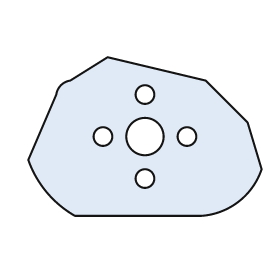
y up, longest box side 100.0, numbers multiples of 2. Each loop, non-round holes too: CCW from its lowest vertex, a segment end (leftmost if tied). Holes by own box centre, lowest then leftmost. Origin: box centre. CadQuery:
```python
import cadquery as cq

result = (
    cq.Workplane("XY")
    .moveTo(-30.0, -34.0)
    .lineTo(24.0, -34.0)
    .threePointArc((40.0, -28.0), (50.0, -14.0))
    .lineTo(44.0, 6.0)
    .lineTo(26.0, 24.0)
    .lineTo(-16.0, 34.0)
    .lineTo(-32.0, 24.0)
    .threePointArc((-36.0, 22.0), (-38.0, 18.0))
    .lineTo(-50.0, -10.0)
    .threePointArc((-42.0, -24.0), (-30.0, -34.0))
    .close()
    .moveTo(0.0, -18.0)
    .circle(4.0)
    .moveTo(-18.0, 0.0)
    .circle(4.0)
    .moveTo(0.0, 0.0)
    .circle(8.0)
    .moveTo(18.0, 0.0)
    .circle(4.0)
    .moveTo(0.0, 18.0)
    .circle(4.0)
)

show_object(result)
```